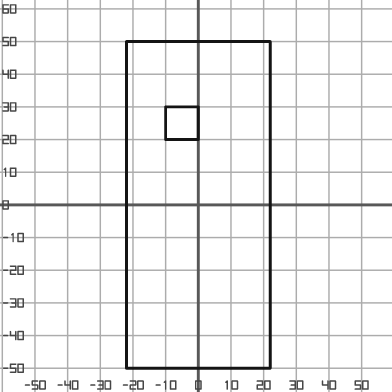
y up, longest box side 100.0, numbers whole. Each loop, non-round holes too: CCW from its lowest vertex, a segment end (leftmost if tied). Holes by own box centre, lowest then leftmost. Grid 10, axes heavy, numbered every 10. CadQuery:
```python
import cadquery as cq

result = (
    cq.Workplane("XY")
    .moveTo(-22.0, -50.0)
    .lineTo(22.0, -50.0)
    .lineTo(22.0, 50.0)
    .lineTo(-22.0, 50.0)
    .close()
    .moveTo(-10.0, 20.0)
    .lineTo(0.0, 20.0)
    .lineTo(0.0, 30.0)
    .lineTo(-10.0, 30.0)
    .close()
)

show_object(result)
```